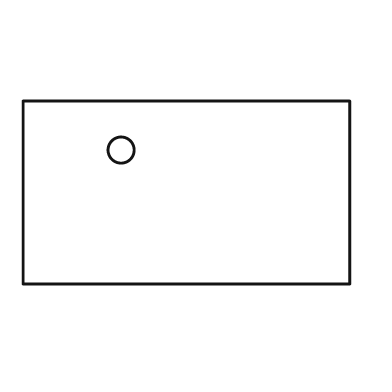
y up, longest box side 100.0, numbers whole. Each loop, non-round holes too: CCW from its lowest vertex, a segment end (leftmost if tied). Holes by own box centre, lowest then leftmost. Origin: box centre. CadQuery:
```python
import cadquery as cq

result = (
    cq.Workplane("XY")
    .moveTo(-50.0, -28.0)
    .lineTo(50.0, -28.0)
    .lineTo(50.0, 28.0)
    .lineTo(-50.0, 28.0)
    .close()
    .moveTo(-20.0, 13.0)
    .circle(4.0)
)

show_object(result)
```